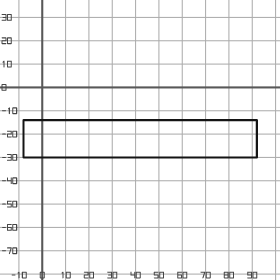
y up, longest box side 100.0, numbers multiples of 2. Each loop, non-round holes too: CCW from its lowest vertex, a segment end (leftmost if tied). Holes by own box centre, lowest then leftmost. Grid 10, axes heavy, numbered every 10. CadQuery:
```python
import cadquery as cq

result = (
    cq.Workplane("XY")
    .moveTo(-8.0, -30.0)
    .lineTo(92.0, -30.0)
    .lineTo(92.0, -14.0)
    .lineTo(-8.0, -14.0)
    .close()
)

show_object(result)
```